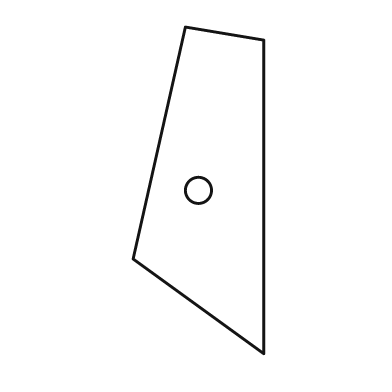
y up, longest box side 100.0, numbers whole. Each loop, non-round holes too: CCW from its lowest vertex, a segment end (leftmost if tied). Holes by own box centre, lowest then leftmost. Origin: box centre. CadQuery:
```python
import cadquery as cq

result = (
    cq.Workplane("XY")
    .moveTo(20.0, -50.0)
    .lineTo(20.0, 46.0)
    .lineTo(-4.0, 50.0)
    .lineTo(-20.0, -21.0)
    .close()
    .moveTo(0.0, 0.0)
    .circle(4.0)
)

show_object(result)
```